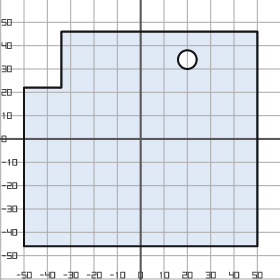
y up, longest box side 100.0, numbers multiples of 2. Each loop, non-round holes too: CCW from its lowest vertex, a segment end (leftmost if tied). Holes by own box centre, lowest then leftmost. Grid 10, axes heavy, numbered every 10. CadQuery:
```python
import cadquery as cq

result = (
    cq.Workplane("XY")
    .moveTo(-50.0, -46.0)
    .lineTo(50.0, -46.0)
    .lineTo(50.0, 46.0)
    .lineTo(-34.0, 46.0)
    .lineTo(-34.0, 22.0)
    .lineTo(-50.0, 22.0)
    .close()
    .moveTo(20.0, 34.0)
    .circle(4.0)
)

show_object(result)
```